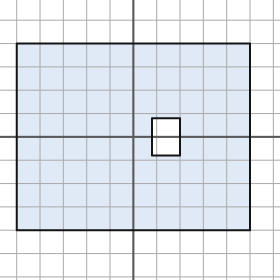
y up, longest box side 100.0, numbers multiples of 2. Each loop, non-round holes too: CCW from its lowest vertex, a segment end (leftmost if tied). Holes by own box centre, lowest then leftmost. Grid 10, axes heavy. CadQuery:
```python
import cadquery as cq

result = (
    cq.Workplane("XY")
    .moveTo(-50.0, -40.0)
    .lineTo(50.0, -40.0)
    .lineTo(50.0, 40.0)
    .lineTo(-50.0, 40.0)
    .close()
    .moveTo(8.0, -8.0)
    .lineTo(20.0, -8.0)
    .lineTo(20.0, 8.0)
    .lineTo(8.0, 8.0)
    .close()
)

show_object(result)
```